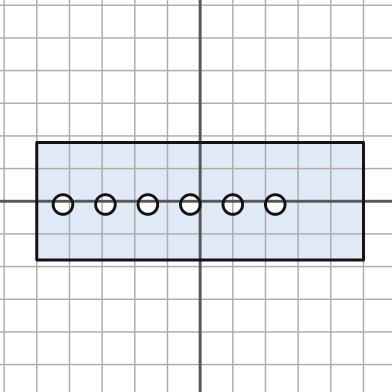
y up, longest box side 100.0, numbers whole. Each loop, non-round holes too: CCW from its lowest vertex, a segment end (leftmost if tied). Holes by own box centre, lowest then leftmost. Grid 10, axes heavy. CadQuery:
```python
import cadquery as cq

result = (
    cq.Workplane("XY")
    .moveTo(-50.0, -18.0)
    .lineTo(50.0, -18.0)
    .lineTo(50.0, 18.0)
    .lineTo(-50.0, 18.0)
    .close()
    .moveTo(-42.0, -1.0)
    .circle(3.0)
    .moveTo(-29.0, -1.0)
    .circle(3.0)
    .moveTo(-16.0, -1.0)
    .circle(3.0)
    .moveTo(-3.0, -1.0)
    .circle(3.0)
    .moveTo(10.0, -1.0)
    .circle(3.0)
    .moveTo(23.0, -1.0)
    .circle(3.0)
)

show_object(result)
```